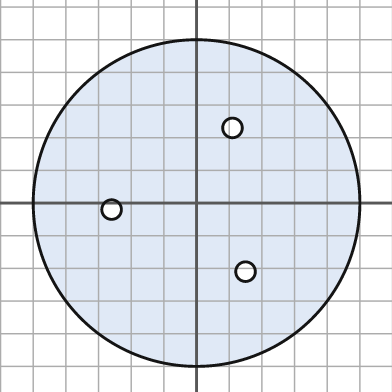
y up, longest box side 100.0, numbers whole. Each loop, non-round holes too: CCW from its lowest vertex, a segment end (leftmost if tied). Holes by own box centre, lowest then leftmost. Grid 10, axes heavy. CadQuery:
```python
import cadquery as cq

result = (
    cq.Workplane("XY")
    .moveTo(0.0, 0.0)
    .circle(50.0)
    .moveTo(15.0, -21.0)
    .circle(3.0)
    .moveTo(-26.0, -2.0)
    .circle(3.0)
    .moveTo(11.0, 23.0)
    .circle(3.0)
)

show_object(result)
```